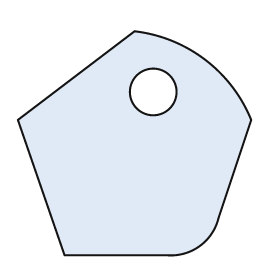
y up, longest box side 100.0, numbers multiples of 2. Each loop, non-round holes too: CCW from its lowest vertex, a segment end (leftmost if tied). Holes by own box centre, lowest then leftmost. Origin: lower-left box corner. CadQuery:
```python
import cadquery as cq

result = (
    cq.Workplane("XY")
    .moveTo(20.0, 0.0)
    .lineTo(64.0, 0.0)
    .threePointArc((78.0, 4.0), (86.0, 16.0))
    .lineTo(100.0, 58.0)
    .threePointArc((80.0, 84.0), (50.0, 96.0))
    .lineTo(0.0, 58.0)
    .close()
    .moveTo(58.0, 70.0)
    .circle(10.0)
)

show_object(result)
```